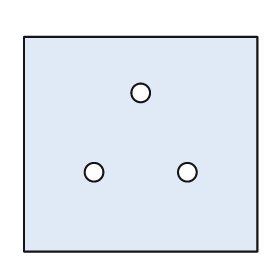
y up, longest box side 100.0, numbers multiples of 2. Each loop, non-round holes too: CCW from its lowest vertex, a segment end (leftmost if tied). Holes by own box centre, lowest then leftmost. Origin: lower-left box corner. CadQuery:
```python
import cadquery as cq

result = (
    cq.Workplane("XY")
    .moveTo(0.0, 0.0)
    .lineTo(100.0, 0.0)
    .lineTo(100.0, 92.0)
    .lineTo(0.0, 92.0)
    .close()
    .moveTo(30.0, 34.0)
    .circle(4.0)
    .moveTo(70.0, 34.0)
    .circle(4.0)
    .moveTo(50.0, 68.0)
    .circle(4.0)
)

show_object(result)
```